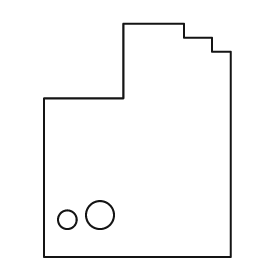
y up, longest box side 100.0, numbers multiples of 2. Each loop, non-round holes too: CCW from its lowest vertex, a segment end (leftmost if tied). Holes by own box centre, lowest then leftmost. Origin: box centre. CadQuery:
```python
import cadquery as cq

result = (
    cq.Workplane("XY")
    .moveTo(-40.0, -50.0)
    .lineTo(40.0, -50.0)
    .lineTo(40.0, 38.0)
    .lineTo(32.0, 38.0)
    .lineTo(32.0, 44.0)
    .lineTo(20.0, 44.0)
    .lineTo(20.0, 50.0)
    .lineTo(-6.0, 50.0)
    .lineTo(-6.0, 18.0)
    .lineTo(-40.0, 18.0)
    .close()
    .moveTo(-30.0, -34.0)
    .circle(4.0)
    .moveTo(-16.0, -32.0)
    .circle(6.0)
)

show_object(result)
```